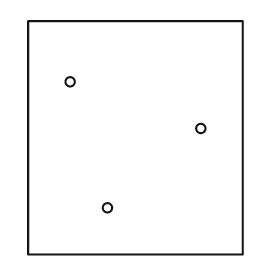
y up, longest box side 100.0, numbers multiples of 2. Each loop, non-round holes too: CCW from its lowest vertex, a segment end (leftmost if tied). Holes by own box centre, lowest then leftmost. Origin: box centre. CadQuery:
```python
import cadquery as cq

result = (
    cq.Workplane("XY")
    .moveTo(-46.0, -50.0)
    .lineTo(46.0, -50.0)
    .lineTo(46.0, 50.0)
    .lineTo(-46.0, 50.0)
    .close()
    .moveTo(-12.0, -30.0)
    .circle(2.0)
    .moveTo(28.0, 4.0)
    .circle(2.0)
    .moveTo(-28.0, 24.0)
    .circle(2.0)
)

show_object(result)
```